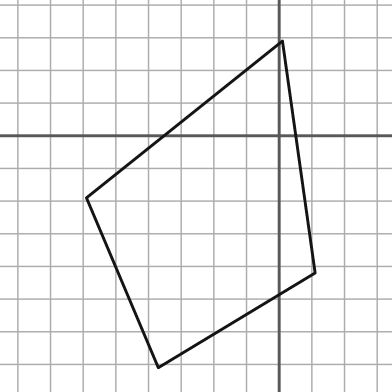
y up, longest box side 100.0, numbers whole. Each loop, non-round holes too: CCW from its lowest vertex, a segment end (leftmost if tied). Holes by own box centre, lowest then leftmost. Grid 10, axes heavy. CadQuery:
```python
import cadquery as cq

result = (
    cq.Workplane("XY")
    .moveTo(-37.0, -71.0)
    .lineTo(11.0, -42.0)
    .lineTo(1.0, 29.0)
    .lineTo(-59.0, -19.0)
    .close()
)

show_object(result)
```